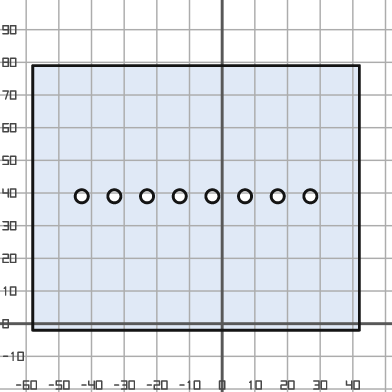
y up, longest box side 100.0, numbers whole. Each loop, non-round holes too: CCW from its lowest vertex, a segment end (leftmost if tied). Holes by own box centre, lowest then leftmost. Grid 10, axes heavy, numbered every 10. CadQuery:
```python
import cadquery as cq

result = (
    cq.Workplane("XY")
    .moveTo(-58.0, -2.0)
    .lineTo(42.0, -2.0)
    .lineTo(42.0, 79.0)
    .lineTo(-58.0, 79.0)
    .close()
    .moveTo(-43.0, 39.0)
    .circle(2.0)
    .moveTo(-33.0, 39.0)
    .circle(2.0)
    .moveTo(-23.0, 39.0)
    .circle(2.0)
    .moveTo(-13.0, 39.0)
    .circle(2.0)
    .moveTo(-3.0, 39.0)
    .circle(2.0)
    .moveTo(7.0, 39.0)
    .circle(2.0)
    .moveTo(17.0, 39.0)
    .circle(2.0)
    .moveTo(27.0, 39.0)
    .circle(2.0)
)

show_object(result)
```